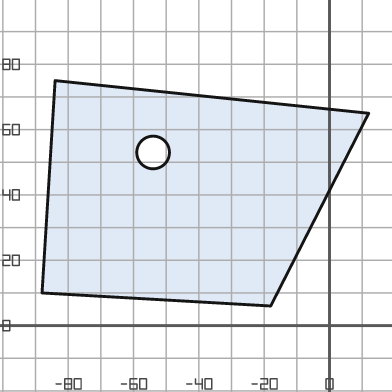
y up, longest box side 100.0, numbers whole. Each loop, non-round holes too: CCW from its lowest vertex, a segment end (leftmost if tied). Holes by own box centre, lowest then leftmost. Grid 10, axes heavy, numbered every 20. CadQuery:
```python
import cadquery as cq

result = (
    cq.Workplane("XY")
    .moveTo(-18.0, 6.0)
    .lineTo(12.0, 65.0)
    .lineTo(-84.0, 75.0)
    .lineTo(-88.0, 10.0)
    .close()
    .moveTo(-54.0, 53.0)
    .circle(5.0)
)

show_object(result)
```